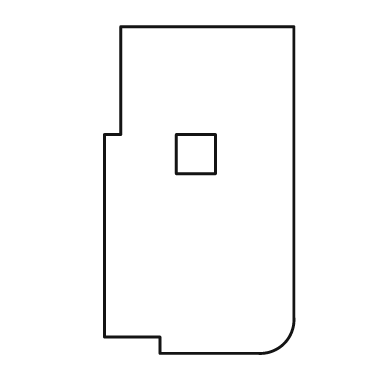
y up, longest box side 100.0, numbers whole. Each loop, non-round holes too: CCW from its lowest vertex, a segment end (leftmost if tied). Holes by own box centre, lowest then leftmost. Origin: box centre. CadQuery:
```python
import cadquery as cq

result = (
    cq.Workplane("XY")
    .moveTo(-12.0, -50.0)
    .lineTo(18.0, -50.0)
    .threePointArc((26.0, -47.0), (29.0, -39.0))
    .lineTo(29.0, 50.0)
    .lineTo(-24.0, 50.0)
    .lineTo(-24.0, 17.0)
    .lineTo(-29.0, 17.0)
    .lineTo(-29.0, -45.0)
    .lineTo(-12.0, -45.0)
    .close()
    .moveTo(-7.0, 5.0)
    .lineTo(5.0, 5.0)
    .lineTo(5.0, 17.0)
    .lineTo(-7.0, 17.0)
    .close()
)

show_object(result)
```